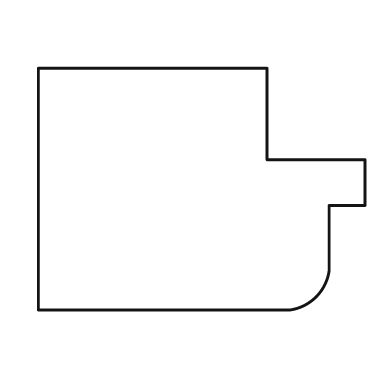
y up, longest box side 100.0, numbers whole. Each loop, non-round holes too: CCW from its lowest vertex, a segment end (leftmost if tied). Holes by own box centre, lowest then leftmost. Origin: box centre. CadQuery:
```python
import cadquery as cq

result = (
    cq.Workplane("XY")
    .moveTo(-50.0, -37.0)
    .lineTo(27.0, -37.0)
    .threePointArc((35.0, -33.0), (39.0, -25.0))
    .lineTo(39.0, -5.0)
    .lineTo(50.0, -5.0)
    .lineTo(50.0, 9.0)
    .lineTo(20.0, 9.0)
    .lineTo(20.0, 37.0)
    .lineTo(-50.0, 37.0)
    .close()
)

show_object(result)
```